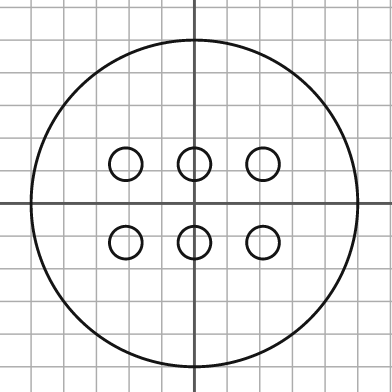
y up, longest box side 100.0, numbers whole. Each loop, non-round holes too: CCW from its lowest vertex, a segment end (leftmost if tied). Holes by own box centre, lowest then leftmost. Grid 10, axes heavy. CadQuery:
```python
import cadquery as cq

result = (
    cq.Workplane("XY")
    .moveTo(0.0, 0.0)
    .circle(50.0)
    .moveTo(-21.0, -12.0)
    .circle(5.0)
    .moveTo(0.0, -12.0)
    .circle(5.0)
    .moveTo(21.0, -12.0)
    .circle(5.0)
    .moveTo(-21.0, 12.0)
    .circle(5.0)
    .moveTo(0.0, 12.0)
    .circle(5.0)
    .moveTo(21.0, 12.0)
    .circle(5.0)
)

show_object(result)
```